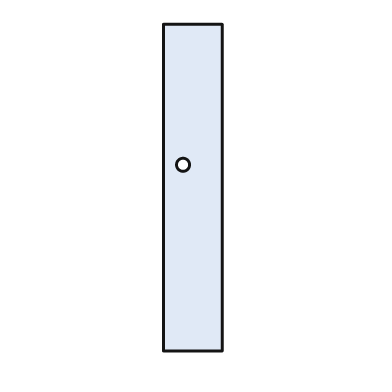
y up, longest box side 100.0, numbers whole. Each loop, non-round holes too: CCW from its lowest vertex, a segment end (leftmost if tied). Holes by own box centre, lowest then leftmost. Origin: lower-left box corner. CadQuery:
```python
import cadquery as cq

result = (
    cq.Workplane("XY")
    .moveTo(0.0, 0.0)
    .lineTo(18.0, 0.0)
    .lineTo(18.0, 100.0)
    .lineTo(0.0, 100.0)
    .close()
    .moveTo(6.0, 57.0)
    .circle(2.0)
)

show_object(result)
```